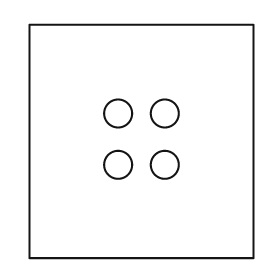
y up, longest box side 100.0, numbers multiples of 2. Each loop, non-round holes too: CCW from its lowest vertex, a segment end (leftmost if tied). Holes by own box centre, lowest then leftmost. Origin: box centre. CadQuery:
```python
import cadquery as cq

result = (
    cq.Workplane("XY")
    .moveTo(-48.0, -50.0)
    .lineTo(48.0, -50.0)
    .lineTo(48.0, 50.0)
    .lineTo(-48.0, 50.0)
    .close()
    .moveTo(-10.0, -10.0)
    .circle(6.0)
    .moveTo(10.0, -10.0)
    .circle(6.0)
    .moveTo(-10.0, 12.0)
    .circle(6.0)
    .moveTo(10.0, 12.0)
    .circle(6.0)
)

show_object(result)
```